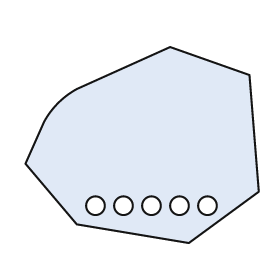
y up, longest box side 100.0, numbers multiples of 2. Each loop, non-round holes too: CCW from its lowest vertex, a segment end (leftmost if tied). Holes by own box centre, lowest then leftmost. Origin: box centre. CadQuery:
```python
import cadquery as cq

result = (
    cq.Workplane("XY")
    .moveTo(20.0, -42.0)
    .lineTo(50.0, -20.0)
    .lineTo(46.0, 30.0)
    .lineTo(12.0, 42.0)
    .lineTo(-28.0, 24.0)
    .threePointArc((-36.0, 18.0), (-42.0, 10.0))
    .lineTo(-50.0, -8.0)
    .lineTo(-28.0, -34.0)
    .close()
    .moveTo(-20.0, -26.0)
    .circle(4.0)
    .moveTo(-8.0, -26.0)
    .circle(4.0)
    .moveTo(4.0, -26.0)
    .circle(4.0)
    .moveTo(16.0, -26.0)
    .circle(4.0)
    .moveTo(28.0, -26.0)
    .circle(4.0)
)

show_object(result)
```